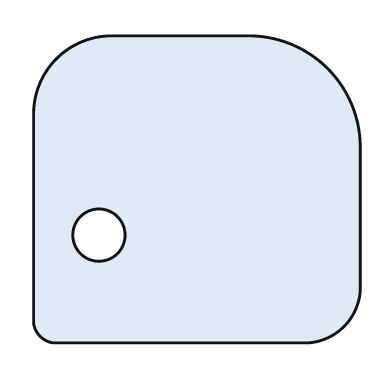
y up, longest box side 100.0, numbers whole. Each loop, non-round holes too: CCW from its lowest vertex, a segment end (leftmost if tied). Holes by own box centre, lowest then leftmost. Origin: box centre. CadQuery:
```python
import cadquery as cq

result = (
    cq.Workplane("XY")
    .moveTo(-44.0, -47.0)
    .lineTo(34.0, -47.0)
    .threePointArc((45.0, -42.0), (50.0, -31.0))
    .lineTo(50.0, 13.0)
    .threePointArc((40.0, 37.0), (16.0, 47.0))
    .lineTo(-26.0, 47.0)
    .threePointArc((-43.0, 40.0), (-50.0, 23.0))
    .lineTo(-50.0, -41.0)
    .threePointArc((-48.0, -45.0), (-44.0, -47.0))
    .close()
    .moveTo(-30.0, -14.0)
    .circle(8.0)
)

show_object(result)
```